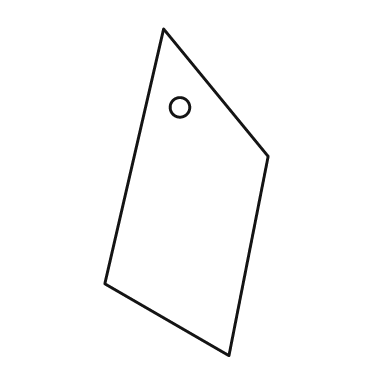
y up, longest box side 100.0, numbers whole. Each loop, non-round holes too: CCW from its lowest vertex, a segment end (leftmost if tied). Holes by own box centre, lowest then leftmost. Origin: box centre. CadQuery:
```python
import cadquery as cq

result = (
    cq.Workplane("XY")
    .moveTo(13.0, -50.0)
    .lineTo(25.0, 11.0)
    .lineTo(-7.0, 50.0)
    .lineTo(-25.0, -28.0)
    .close()
    .moveTo(-2.0, 26.0)
    .circle(3.0)
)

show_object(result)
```